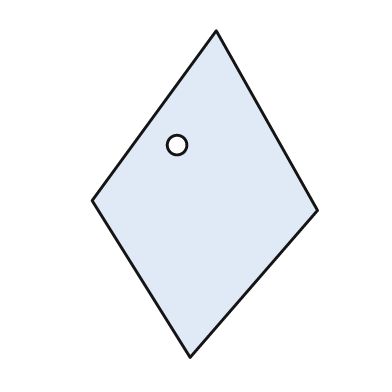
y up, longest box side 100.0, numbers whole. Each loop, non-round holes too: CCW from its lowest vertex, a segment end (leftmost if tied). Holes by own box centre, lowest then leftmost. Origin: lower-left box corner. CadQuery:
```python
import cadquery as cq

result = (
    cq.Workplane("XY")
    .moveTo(30.0, 0.0)
    .lineTo(69.0, 45.0)
    .lineTo(38.0, 100.0)
    .lineTo(0.0, 48.0)
    .close()
    .moveTo(26.0, 65.0)
    .circle(3.0)
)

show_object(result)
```